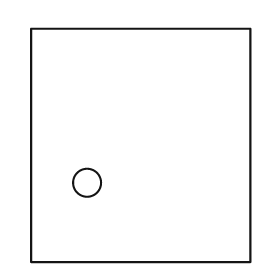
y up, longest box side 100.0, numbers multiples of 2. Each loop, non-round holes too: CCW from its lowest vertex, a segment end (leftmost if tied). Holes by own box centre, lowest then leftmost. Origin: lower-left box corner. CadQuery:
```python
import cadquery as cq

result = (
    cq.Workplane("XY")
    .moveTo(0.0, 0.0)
    .lineTo(94.0, 0.0)
    .lineTo(94.0, 100.0)
    .lineTo(0.0, 100.0)
    .close()
    .moveTo(24.0, 34.0)
    .circle(6.0)
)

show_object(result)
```